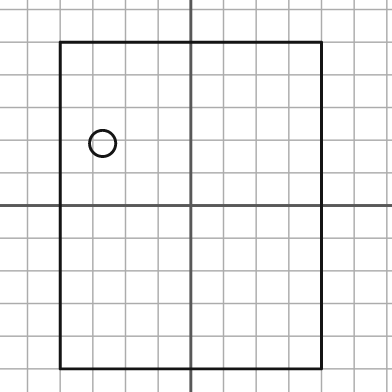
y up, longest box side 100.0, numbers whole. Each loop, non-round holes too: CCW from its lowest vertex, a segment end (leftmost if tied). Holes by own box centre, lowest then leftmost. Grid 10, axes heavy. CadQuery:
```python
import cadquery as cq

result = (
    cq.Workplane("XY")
    .moveTo(-40.0, -50.0)
    .lineTo(40.0, -50.0)
    .lineTo(40.0, 50.0)
    .lineTo(-40.0, 50.0)
    .close()
    .moveTo(-27.0, 19.0)
    .circle(4.0)
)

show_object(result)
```